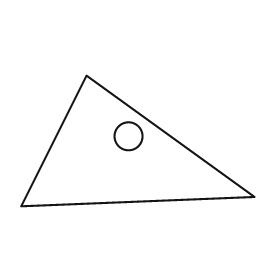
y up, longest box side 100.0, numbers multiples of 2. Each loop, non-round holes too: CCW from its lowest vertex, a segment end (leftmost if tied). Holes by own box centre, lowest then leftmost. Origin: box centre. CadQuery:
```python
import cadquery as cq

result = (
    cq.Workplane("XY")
    .moveTo(-50.0, -28.0)
    .lineTo(50.0, -24.0)
    .lineTo(-22.0, 28.0)
    .close()
    .moveTo(-4.0, 2.0)
    .circle(6.0)
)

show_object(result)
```